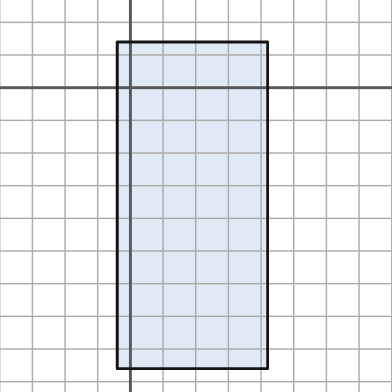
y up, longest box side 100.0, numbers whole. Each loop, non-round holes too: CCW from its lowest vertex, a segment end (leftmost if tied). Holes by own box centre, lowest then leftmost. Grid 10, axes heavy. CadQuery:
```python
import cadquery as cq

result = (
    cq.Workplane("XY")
    .moveTo(-4.0, -86.0)
    .lineTo(42.0, -86.0)
    .lineTo(42.0, 14.0)
    .lineTo(-4.0, 14.0)
    .close()
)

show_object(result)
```